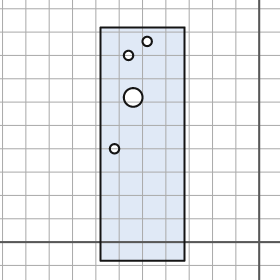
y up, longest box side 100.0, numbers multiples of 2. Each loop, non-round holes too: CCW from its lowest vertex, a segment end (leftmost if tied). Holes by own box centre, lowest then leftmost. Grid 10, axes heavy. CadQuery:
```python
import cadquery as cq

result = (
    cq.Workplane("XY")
    .moveTo(-68.0, -8.0)
    .lineTo(-32.0, -8.0)
    .lineTo(-32.0, 92.0)
    .lineTo(-68.0, 92.0)
    .close()
    .moveTo(-62.0, 40.0)
    .circle(2.0)
    .moveTo(-54.0, 62.0)
    .circle(4.0)
    .moveTo(-56.0, 80.0)
    .circle(2.0)
    .moveTo(-48.0, 86.0)
    .circle(2.0)
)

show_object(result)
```